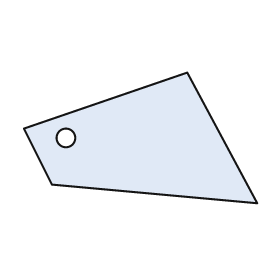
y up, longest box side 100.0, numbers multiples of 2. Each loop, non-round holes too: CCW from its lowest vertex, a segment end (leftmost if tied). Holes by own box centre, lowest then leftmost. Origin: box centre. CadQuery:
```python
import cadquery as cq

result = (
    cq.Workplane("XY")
    .moveTo(50.0, -28.0)
    .lineTo(20.0, 28.0)
    .lineTo(-50.0, 4.0)
    .lineTo(-38.0, -20.0)
    .close()
    .moveTo(-32.0, 0.0)
    .circle(4.0)
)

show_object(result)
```